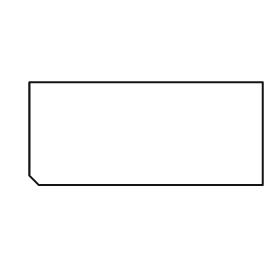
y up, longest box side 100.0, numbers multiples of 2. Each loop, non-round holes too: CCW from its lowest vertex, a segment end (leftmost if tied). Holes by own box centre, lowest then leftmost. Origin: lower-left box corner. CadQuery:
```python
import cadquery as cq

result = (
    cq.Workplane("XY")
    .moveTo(4.0, 0.0)
    .lineTo(100.0, 0.0)
    .lineTo(100.0, 44.0)
    .lineTo(0.0, 44.0)
    .lineTo(0.0, 4.0)
    .close()
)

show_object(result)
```